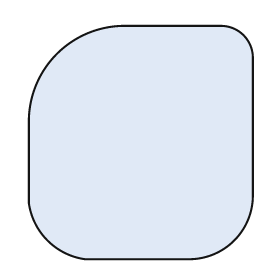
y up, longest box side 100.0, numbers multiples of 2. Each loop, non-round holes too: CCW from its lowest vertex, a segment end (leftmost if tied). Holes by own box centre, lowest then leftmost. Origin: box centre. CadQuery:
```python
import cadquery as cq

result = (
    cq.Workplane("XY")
    .moveTo(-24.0, -50.0)
    .lineTo(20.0, -50.0)
    .threePointArc((40.0, -42.0), (48.0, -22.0))
    .lineTo(48.0, 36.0)
    .threePointArc((44.0, 46.0), (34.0, 50.0))
    .lineTo(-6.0, 50.0)
    .threePointArc((-36.0, 38.0), (-48.0, 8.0))
    .lineTo(-48.0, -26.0)
    .threePointArc((-40.0, -42.0), (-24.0, -50.0))
    .close()
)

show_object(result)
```